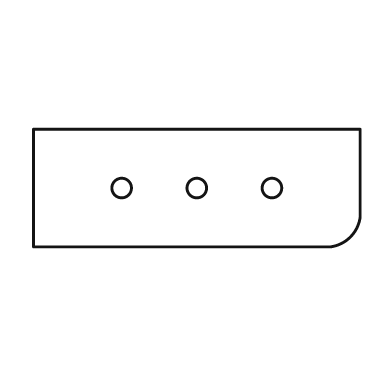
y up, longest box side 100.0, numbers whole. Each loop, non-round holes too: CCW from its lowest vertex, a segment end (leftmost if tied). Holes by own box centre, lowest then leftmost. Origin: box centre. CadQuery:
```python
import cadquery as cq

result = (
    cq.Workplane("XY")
    .moveTo(-50.0, -18.0)
    .lineTo(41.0, -18.0)
    .threePointArc((47.0, -15.0), (50.0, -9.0))
    .lineTo(50.0, 18.0)
    .lineTo(-50.0, 18.0)
    .close()
    .moveTo(-23.0, 0.0)
    .circle(3.0)
    .moveTo(0.0, 0.0)
    .circle(3.0)
    .moveTo(23.0, 0.0)
    .circle(3.0)
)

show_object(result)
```